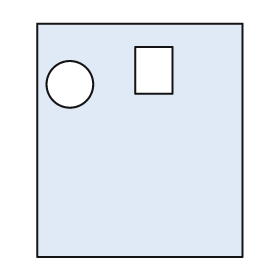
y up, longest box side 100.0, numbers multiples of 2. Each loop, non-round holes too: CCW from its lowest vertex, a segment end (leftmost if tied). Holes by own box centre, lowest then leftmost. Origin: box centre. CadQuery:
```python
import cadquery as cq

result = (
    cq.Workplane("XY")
    .moveTo(-44.0, -50.0)
    .lineTo(44.0, -50.0)
    .lineTo(44.0, 50.0)
    .lineTo(-44.0, 50.0)
    .close()
    .moveTo(-30.0, 24.0)
    .circle(10.0)
    .moveTo(-2.0, 20.0)
    .lineTo(14.0, 20.0)
    .lineTo(14.0, 40.0)
    .lineTo(-2.0, 40.0)
    .close()
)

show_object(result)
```